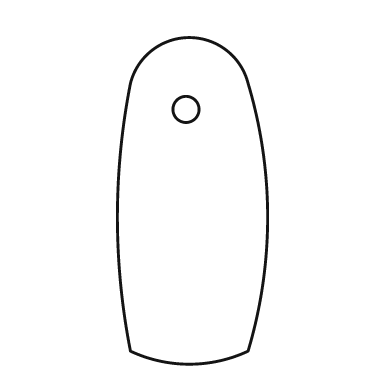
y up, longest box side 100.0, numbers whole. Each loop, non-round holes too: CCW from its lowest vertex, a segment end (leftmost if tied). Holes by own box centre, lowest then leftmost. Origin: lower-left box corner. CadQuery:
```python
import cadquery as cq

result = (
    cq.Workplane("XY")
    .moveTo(4.0, 4.0)
    .threePointArc((22.0, 0.0), (40.0, 4.0))
    .threePointArc((46.0, 45.0), (40.0, 86.0))
    .threePointArc((22.0, 100.0), (4.0, 86.0))
    .threePointArc((0.0, 45.0), (4.0, 4.0))
    .close()
    .moveTo(21.0, 78.0)
    .circle(4.0)
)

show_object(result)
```